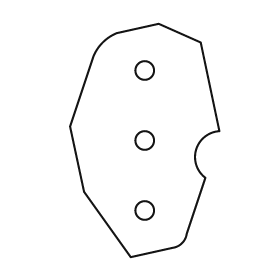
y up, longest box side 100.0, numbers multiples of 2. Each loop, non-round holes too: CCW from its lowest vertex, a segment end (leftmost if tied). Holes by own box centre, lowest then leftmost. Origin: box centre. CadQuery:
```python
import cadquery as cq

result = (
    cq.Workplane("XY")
    .moveTo(-6.0, -50.0)
    .lineTo(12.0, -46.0)
    .threePointArc((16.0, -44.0), (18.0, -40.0))
    .lineTo(26.0, -16.0)
    .threePointArc((22.0, -4.0), (32.0, 4.0))
    .lineTo(24.0, 42.0)
    .lineTo(6.0, 50.0)
    .lineTo(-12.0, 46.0)
    .threePointArc((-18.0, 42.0), (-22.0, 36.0))
    .lineTo(-32.0, 6.0)
    .lineTo(-26.0, -22.0)
    .close()
    .moveTo(0.0, -30.0)
    .circle(4.0)
    .moveTo(0.0, 0.0)
    .circle(4.0)
    .moveTo(0.0, 30.0)
    .circle(4.0)
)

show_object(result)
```